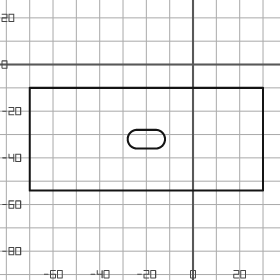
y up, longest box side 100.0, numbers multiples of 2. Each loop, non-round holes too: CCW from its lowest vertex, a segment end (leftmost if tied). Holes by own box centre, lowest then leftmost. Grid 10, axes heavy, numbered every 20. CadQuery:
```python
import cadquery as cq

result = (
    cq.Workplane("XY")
    .moveTo(-70.0, -54.0)
    .lineTo(30.0, -54.0)
    .lineTo(30.0, -10.0)
    .lineTo(-70.0, -10.0)
    .close()
    .moveTo(-24.0, -36.0)
    .lineTo(-16.0, -36.0)
    .threePointArc((-12.0, -32.0), (-16.0, -28.0))
    .lineTo(-24.0, -28.0)
    .threePointArc((-28.0, -32.0), (-24.0, -36.0))
    .close()
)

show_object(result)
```